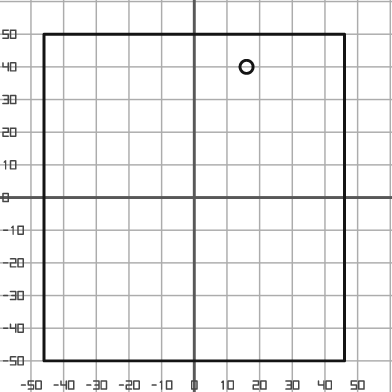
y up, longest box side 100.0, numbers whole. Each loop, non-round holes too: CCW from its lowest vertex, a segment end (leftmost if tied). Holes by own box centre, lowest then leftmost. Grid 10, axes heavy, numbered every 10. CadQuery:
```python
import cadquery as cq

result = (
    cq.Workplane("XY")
    .moveTo(-46.0, -50.0)
    .lineTo(46.0, -50.0)
    .lineTo(46.0, 50.0)
    .lineTo(-46.0, 50.0)
    .close()
    .moveTo(16.0, 40.0)
    .circle(2.0)
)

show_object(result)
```